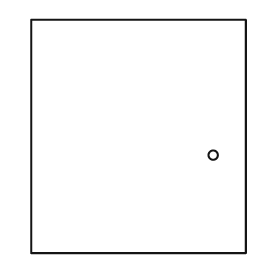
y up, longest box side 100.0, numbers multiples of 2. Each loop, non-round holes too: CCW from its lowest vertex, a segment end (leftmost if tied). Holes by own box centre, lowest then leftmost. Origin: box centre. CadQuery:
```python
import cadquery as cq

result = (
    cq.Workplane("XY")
    .moveTo(-46.0, -50.0)
    .lineTo(46.0, -50.0)
    .lineTo(46.0, 50.0)
    .lineTo(-46.0, 50.0)
    .close()
    .moveTo(32.0, -8.0)
    .circle(2.0)
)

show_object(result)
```